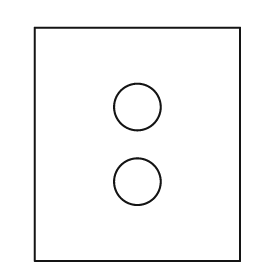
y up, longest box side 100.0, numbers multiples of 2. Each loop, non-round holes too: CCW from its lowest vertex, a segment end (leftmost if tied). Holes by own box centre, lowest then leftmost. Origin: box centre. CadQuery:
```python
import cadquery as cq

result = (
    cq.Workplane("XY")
    .moveTo(-44.0, -50.0)
    .lineTo(44.0, -50.0)
    .lineTo(44.0, 50.0)
    .lineTo(-44.0, 50.0)
    .close()
    .moveTo(0.0, -16.0)
    .circle(10.0)
    .moveTo(0.0, 16.0)
    .circle(10.0)
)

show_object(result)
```